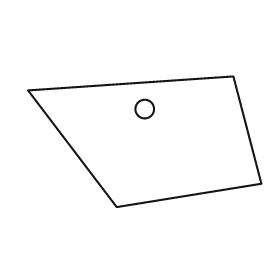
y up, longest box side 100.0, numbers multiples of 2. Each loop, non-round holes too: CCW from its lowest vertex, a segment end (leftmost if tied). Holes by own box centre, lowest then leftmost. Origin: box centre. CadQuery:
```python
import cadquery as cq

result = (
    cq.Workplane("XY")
    .moveTo(-12.0, -28.0)
    .lineTo(50.0, -18.0)
    .lineTo(38.0, 28.0)
    .lineTo(-50.0, 22.0)
    .close()
    .moveTo(0.0, 14.0)
    .circle(4.0)
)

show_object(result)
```